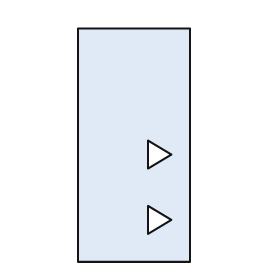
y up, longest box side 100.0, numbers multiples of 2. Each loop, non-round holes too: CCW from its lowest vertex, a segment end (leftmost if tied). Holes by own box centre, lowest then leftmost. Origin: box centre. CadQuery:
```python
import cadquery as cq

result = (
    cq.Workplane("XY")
    .moveTo(-24.0, -50.0)
    .lineTo(24.0, -50.0)
    .lineTo(24.0, 50.0)
    .lineTo(-24.0, 50.0)
    .close()
    .moveTo(6.0, -38.0)
    .lineTo(16.0, -32.0)
    .lineTo(6.0, -26.0)
    .close()
    .moveTo(6.0, -10.0)
    .lineTo(16.0, -4.0)
    .lineTo(6.0, 2.0)
    .close()
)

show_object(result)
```